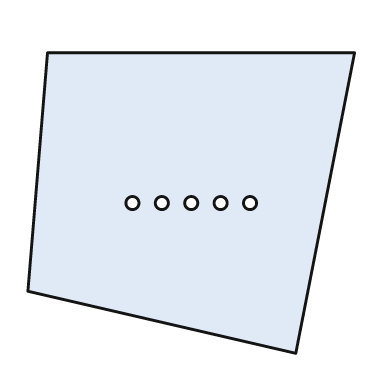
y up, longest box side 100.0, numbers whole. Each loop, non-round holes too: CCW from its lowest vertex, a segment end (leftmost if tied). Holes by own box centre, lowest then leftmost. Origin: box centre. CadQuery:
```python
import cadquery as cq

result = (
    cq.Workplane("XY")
    .moveTo(32.0, -46.0)
    .lineTo(50.0, 46.0)
    .lineTo(-44.0, 46.0)
    .lineTo(-50.0, -27.0)
    .close()
    .moveTo(-18.0, 0.0)
    .circle(2.0)
    .moveTo(-9.0, 0.0)
    .circle(2.0)
    .moveTo(0.0, 0.0)
    .circle(2.0)
    .moveTo(9.0, 0.0)
    .circle(2.0)
    .moveTo(18.0, 0.0)
    .circle(2.0)
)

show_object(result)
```